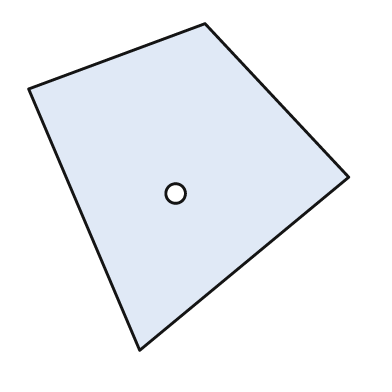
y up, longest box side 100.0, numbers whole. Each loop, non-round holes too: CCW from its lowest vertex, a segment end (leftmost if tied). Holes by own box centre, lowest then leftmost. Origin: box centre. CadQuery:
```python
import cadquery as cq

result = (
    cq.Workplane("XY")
    .moveTo(-15.0, -50.0)
    .lineTo(49.0, 3.0)
    .lineTo(5.0, 50.0)
    .lineTo(-49.0, 30.0)
    .close()
    .moveTo(-4.0, -2.0)
    .circle(3.0)
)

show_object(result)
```